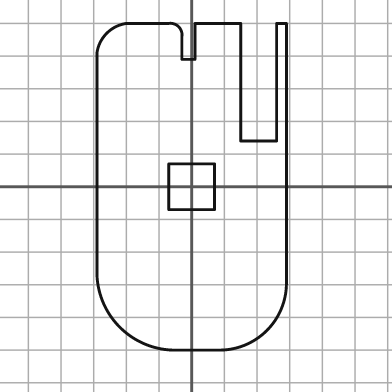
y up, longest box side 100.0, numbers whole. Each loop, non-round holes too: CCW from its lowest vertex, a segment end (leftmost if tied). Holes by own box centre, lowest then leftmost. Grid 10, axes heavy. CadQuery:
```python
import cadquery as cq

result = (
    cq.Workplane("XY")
    .moveTo(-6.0, -50.0)
    .lineTo(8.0, -50.0)
    .threePointArc((23.0, -44.0), (29.0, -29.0))
    .lineTo(29.0, 50.0)
    .lineTo(26.0, 50.0)
    .lineTo(26.0, 14.0)
    .lineTo(15.0, 14.0)
    .lineTo(15.0, 50.0)
    .lineTo(1.0, 50.0)
    .lineTo(1.0, 39.0)
    .lineTo(-3.0, 39.0)
    .lineTo(-3.0, 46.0)
    .threePointArc((-4.0, 49.0), (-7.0, 50.0))
    .lineTo(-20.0, 50.0)
    .threePointArc((-26.0, 47.0), (-29.0, 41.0))
    .lineTo(-29.0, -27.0)
    .threePointArc((-22.0, -43.0), (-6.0, -50.0))
    .close()
    .moveTo(-7.0, -7.0)
    .lineTo(7.0, -7.0)
    .lineTo(7.0, 7.0)
    .lineTo(-7.0, 7.0)
    .close()
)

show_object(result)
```